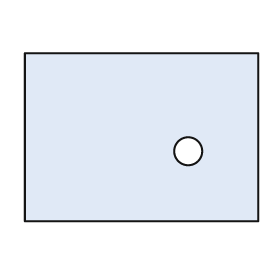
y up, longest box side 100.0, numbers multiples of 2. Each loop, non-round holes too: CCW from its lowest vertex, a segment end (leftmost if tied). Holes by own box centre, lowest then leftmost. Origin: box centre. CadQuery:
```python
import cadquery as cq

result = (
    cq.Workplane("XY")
    .moveTo(-50.0, -36.0)
    .lineTo(50.0, -36.0)
    .lineTo(50.0, 36.0)
    .lineTo(-50.0, 36.0)
    .close()
    .moveTo(20.0, -6.0)
    .circle(6.0)
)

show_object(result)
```